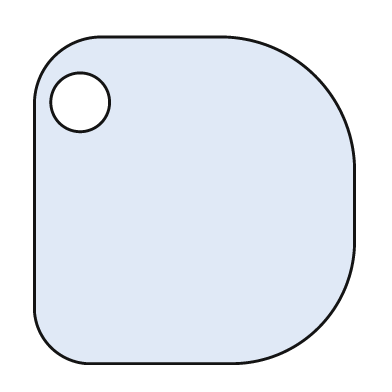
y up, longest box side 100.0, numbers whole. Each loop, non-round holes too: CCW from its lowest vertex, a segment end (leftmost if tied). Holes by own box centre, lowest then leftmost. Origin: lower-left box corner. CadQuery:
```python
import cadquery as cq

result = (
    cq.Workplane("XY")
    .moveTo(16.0, 0.0)
    .lineTo(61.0, 0.0)
    .threePointArc((87.0, 11.0), (98.0, 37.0))
    .lineTo(98.0, 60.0)
    .threePointArc((86.0, 88.0), (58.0, 100.0))
    .lineTo(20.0, 100.0)
    .threePointArc((6.0, 94.0), (0.0, 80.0))
    .lineTo(0.0, 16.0)
    .threePointArc((5.0, 5.0), (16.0, 0.0))
    .close()
    .moveTo(14.0, 80.0)
    .circle(9.0)
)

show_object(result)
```